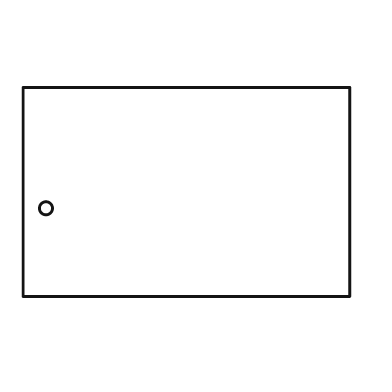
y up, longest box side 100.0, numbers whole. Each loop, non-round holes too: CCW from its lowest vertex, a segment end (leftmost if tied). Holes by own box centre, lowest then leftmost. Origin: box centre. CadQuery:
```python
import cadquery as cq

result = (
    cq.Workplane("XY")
    .moveTo(-50.0, -32.0)
    .lineTo(50.0, -32.0)
    .lineTo(50.0, 32.0)
    .lineTo(-50.0, 32.0)
    .close()
    .moveTo(-43.0, -5.0)
    .circle(2.0)
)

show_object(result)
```